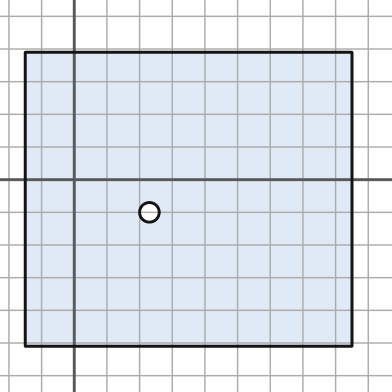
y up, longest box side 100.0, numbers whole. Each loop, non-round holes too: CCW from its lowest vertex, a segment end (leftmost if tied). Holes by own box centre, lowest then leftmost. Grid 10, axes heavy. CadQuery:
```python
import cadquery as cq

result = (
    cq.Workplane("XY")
    .moveTo(-15.0, -51.0)
    .lineTo(85.0, -51.0)
    .lineTo(85.0, 39.0)
    .lineTo(-15.0, 39.0)
    .close()
    .moveTo(23.0, -10.0)
    .circle(3.0)
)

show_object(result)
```